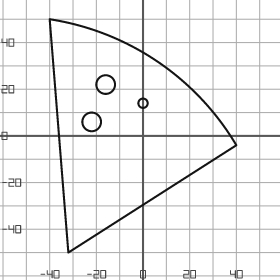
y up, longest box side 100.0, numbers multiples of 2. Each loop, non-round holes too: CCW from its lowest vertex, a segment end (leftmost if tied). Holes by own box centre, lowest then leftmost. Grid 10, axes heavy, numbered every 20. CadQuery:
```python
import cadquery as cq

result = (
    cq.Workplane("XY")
    .moveTo(-32.0, -50.0)
    .lineTo(40.0, -4.0)
    .threePointArc((6.0, 32.0), (-40.0, 50.0))
    .close()
    .moveTo(-22.0, 6.0)
    .circle(4.0)
    .moveTo(0.0, 14.0)
    .circle(2.0)
    .moveTo(-16.0, 22.0)
    .circle(4.0)
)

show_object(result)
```